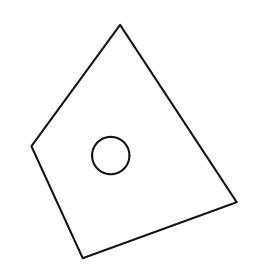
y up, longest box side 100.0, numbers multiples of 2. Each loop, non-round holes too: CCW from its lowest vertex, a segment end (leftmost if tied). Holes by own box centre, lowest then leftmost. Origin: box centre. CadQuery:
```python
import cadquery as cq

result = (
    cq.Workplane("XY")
    .moveTo(-22.0, -50.0)
    .lineTo(44.0, -26.0)
    .lineTo(-6.0, 50.0)
    .lineTo(-44.0, -2.0)
    .close()
    .moveTo(-10.0, -6.0)
    .circle(8.0)
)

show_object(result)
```